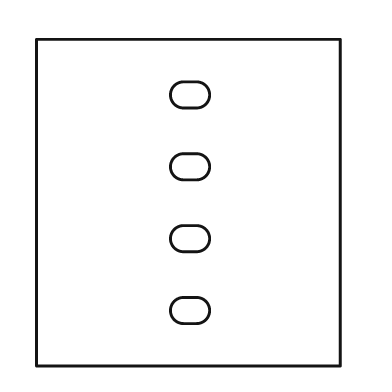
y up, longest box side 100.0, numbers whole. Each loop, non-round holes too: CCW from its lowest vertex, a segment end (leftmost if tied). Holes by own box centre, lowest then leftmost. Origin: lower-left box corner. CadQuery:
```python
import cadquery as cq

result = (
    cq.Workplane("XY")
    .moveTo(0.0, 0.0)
    .lineTo(93.0, 0.0)
    .lineTo(93.0, 100.0)
    .lineTo(0.0, 100.0)
    .close()
    .moveTo(45.0, 13.0)
    .lineTo(49.0, 13.0)
    .threePointArc((53.0, 17.0), (49.0, 21.0))
    .lineTo(45.0, 21.0)
    .threePointArc((41.0, 17.0), (45.0, 13.0))
    .close()
    .moveTo(45.0, 35.0)
    .lineTo(49.0, 35.0)
    .threePointArc((53.0, 39.0), (49.0, 43.0))
    .lineTo(45.0, 43.0)
    .threePointArc((41.0, 39.0), (45.0, 35.0))
    .close()
    .moveTo(45.0, 57.0)
    .lineTo(49.0, 57.0)
    .threePointArc((53.0, 61.0), (49.0, 65.0))
    .lineTo(45.0, 65.0)
    .threePointArc((41.0, 61.0), (45.0, 57.0))
    .close()
    .moveTo(45.0, 79.0)
    .lineTo(49.0, 79.0)
    .threePointArc((53.0, 83.0), (49.0, 87.0))
    .lineTo(45.0, 87.0)
    .threePointArc((41.0, 83.0), (45.0, 79.0))
    .close()
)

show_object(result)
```